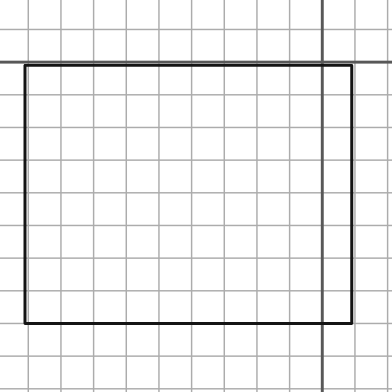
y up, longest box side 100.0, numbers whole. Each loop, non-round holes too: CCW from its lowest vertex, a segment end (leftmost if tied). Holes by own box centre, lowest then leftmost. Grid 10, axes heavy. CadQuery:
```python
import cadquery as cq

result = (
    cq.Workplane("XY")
    .moveTo(-91.0, -80.0)
    .lineTo(9.0, -80.0)
    .lineTo(9.0, -1.0)
    .lineTo(-91.0, -1.0)
    .close()
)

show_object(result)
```